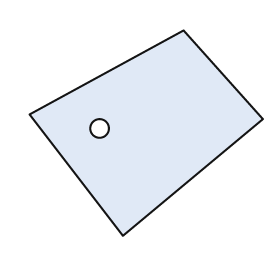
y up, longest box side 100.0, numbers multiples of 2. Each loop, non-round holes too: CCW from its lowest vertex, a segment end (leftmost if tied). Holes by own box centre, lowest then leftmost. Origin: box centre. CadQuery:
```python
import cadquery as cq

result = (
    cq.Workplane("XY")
    .moveTo(-10.0, -44.0)
    .lineTo(50.0, 6.0)
    .lineTo(16.0, 44.0)
    .lineTo(-50.0, 8.0)
    .close()
    .moveTo(-20.0, 2.0)
    .circle(4.0)
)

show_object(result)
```